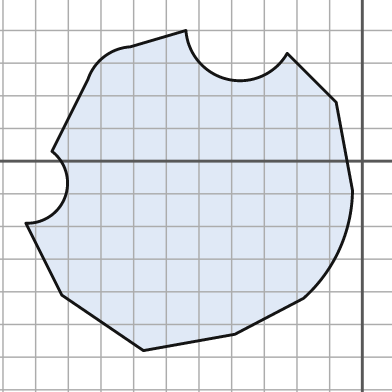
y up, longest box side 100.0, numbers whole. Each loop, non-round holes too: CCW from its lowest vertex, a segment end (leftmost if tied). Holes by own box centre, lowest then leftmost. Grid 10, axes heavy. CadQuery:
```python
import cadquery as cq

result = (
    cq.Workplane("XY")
    .moveTo(-67.0, -58.0)
    .lineTo(-39.0, -53.0)
    .lineTo(-18.0, -42.0)
    .threePointArc((-7.0, -27.0), (-3.0, -9.0))
    .lineTo(-8.0, 18.0)
    .lineTo(-23.0, 33.0)
    .threePointArc((-41.0, 25.0), (-54.0, 40.0))
    .lineTo(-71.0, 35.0)
    .threePointArc((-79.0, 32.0), (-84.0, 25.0))
    .lineTo(-95.0, 3.0)
    .threePointArc((-91.0, -11.0), (-103.0, -19.0))
    .lineTo(-92.0, -41.0)
    .close()
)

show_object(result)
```